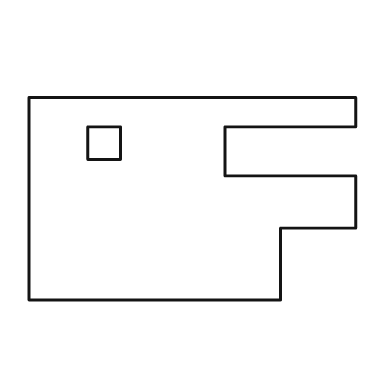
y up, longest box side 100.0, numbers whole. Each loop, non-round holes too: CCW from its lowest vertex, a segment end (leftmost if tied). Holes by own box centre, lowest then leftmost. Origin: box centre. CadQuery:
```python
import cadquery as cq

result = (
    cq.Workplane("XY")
    .moveTo(-50.0, -31.0)
    .lineTo(27.0, -31.0)
    .lineTo(27.0, -9.0)
    .lineTo(50.0, -9.0)
    .lineTo(50.0, 7.0)
    .lineTo(10.0, 7.0)
    .lineTo(10.0, 22.0)
    .lineTo(50.0, 22.0)
    .lineTo(50.0, 31.0)
    .lineTo(-50.0, 31.0)
    .close()
    .moveTo(-32.0, 12.0)
    .lineTo(-22.0, 12.0)
    .lineTo(-22.0, 22.0)
    .lineTo(-32.0, 22.0)
    .close()
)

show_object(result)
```